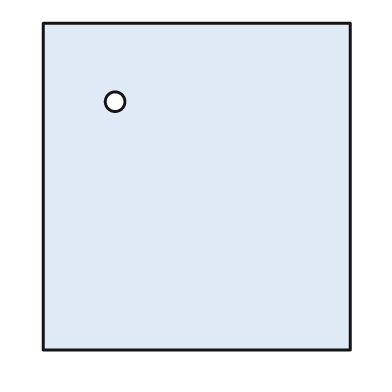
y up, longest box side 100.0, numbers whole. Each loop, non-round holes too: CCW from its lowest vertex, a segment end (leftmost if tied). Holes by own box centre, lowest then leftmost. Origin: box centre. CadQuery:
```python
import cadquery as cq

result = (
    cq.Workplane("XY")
    .moveTo(-47.0, -50.0)
    .lineTo(47.0, -50.0)
    .lineTo(47.0, 50.0)
    .lineTo(-47.0, 50.0)
    .close()
    .moveTo(-25.0, 26.0)
    .circle(3.0)
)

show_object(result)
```